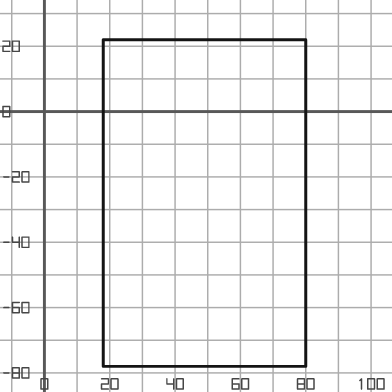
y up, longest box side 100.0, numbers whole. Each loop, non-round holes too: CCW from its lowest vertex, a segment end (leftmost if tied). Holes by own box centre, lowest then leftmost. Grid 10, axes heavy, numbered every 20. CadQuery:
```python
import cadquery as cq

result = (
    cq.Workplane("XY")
    .moveTo(18.0, -78.0)
    .lineTo(80.0, -78.0)
    .lineTo(80.0, 22.0)
    .lineTo(18.0, 22.0)
    .close()
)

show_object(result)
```